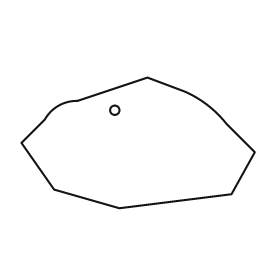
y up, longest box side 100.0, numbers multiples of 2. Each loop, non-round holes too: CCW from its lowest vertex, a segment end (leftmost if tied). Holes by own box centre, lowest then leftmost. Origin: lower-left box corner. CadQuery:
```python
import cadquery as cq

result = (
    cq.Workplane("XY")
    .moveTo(42.0, 0.0)
    .lineTo(90.0, 6.0)
    .lineTo(100.0, 24.0)
    .lineTo(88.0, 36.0)
    .threePointArc((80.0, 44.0), (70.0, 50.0))
    .lineTo(54.0, 56.0)
    .lineTo(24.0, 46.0)
    .threePointArc((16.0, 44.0), (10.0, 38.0))
    .lineTo(0.0, 28.0)
    .lineTo(14.0, 8.0)
    .close()
    .moveTo(40.0, 42.0)
    .circle(2.0)
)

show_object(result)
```